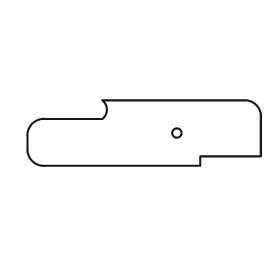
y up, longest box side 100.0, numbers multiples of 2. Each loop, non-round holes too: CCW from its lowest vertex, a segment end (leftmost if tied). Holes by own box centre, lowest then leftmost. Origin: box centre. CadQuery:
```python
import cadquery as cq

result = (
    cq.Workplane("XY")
    .moveTo(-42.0, -14.0)
    .lineTo(24.0, -14.0)
    .lineTo(24.0, -10.0)
    .lineTo(50.0, -10.0)
    .lineTo(50.0, 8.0)
    .threePointArc((48.0, 12.0), (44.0, 14.0))
    .lineTo(-18.0, 14.0)
    .threePointArc((-16.0, 10.0), (-18.0, 6.0))
    .lineTo(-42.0, 6.0)
    .threePointArc((-48.0, 4.0), (-50.0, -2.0))
    .lineTo(-50.0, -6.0)
    .threePointArc((-48.0, -12.0), (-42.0, -14.0))
    .close()
    .moveTo(14.0, 0.0)
    .circle(2.0)
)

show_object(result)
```